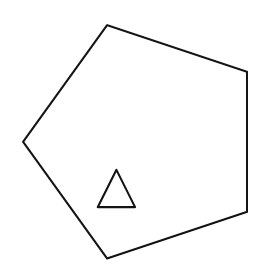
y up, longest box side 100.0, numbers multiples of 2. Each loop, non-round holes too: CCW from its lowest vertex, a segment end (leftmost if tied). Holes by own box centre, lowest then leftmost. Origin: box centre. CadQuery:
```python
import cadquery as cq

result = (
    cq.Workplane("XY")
    .moveTo(-12.0, -50.0)
    .lineTo(48.0, -30.0)
    .lineTo(48.0, 30.0)
    .lineTo(-12.0, 50.0)
    .lineTo(-48.0, 0.0)
    .close()
    .moveTo(-16.0, -28.0)
    .lineTo(0.0, -28.0)
    .lineTo(-8.0, -12.0)
    .close()
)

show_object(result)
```